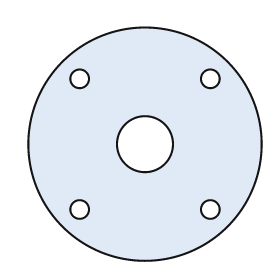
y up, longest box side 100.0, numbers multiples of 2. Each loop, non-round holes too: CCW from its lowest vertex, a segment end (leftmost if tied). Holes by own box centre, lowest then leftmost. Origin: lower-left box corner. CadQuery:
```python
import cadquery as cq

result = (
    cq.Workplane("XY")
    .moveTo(50.0, 50.0)
    .circle(50.0)
    .moveTo(22.0, 22.0)
    .circle(4.0)
    .moveTo(78.0, 22.0)
    .circle(4.0)
    .moveTo(50.0, 50.0)
    .circle(12.0)
    .moveTo(22.0, 78.0)
    .circle(4.0)
    .moveTo(78.0, 78.0)
    .circle(4.0)
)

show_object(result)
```